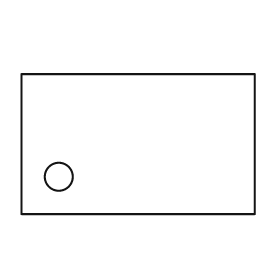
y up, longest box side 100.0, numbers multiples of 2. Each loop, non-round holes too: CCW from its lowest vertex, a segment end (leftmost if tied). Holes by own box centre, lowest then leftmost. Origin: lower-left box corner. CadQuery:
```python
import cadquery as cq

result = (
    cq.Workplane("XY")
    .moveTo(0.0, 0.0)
    .lineTo(100.0, 0.0)
    .lineTo(100.0, 60.0)
    .lineTo(0.0, 60.0)
    .close()
    .moveTo(16.0, 16.0)
    .circle(6.0)
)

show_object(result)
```